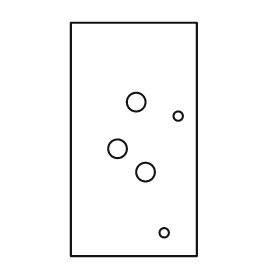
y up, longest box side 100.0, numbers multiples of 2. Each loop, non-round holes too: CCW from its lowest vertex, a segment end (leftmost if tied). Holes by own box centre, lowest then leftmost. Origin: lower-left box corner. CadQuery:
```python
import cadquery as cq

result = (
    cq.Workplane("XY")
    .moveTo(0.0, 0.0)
    .lineTo(54.0, 0.0)
    .lineTo(54.0, 100.0)
    .lineTo(0.0, 100.0)
    .close()
    .moveTo(40.0, 10.0)
    .circle(2.0)
    .moveTo(32.0, 36.0)
    .circle(4.0)
    .moveTo(20.0, 46.0)
    .circle(4.0)
    .moveTo(46.0, 60.0)
    .circle(2.0)
    .moveTo(28.0, 66.0)
    .circle(4.0)
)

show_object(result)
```